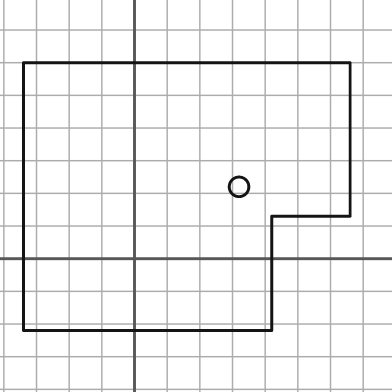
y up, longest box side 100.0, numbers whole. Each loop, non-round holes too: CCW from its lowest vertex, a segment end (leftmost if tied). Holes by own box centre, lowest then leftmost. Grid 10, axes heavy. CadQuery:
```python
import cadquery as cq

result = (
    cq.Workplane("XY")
    .moveTo(-34.0, -22.0)
    .lineTo(42.0, -22.0)
    .lineTo(42.0, 13.0)
    .lineTo(66.0, 13.0)
    .lineTo(66.0, 60.0)
    .lineTo(-34.0, 60.0)
    .close()
    .moveTo(32.0, 22.0)
    .circle(3.0)
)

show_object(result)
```